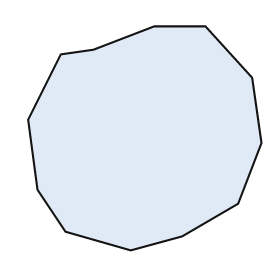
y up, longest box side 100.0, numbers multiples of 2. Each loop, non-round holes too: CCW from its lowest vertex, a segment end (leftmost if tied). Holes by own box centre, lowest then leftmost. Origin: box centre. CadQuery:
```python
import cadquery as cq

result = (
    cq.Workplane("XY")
    .moveTo(-6.0, -48.0)
    .lineTo(16.0, -42.0)
    .lineTo(40.0, -28.0)
    .lineTo(50.0, -2.0)
    .lineTo(46.0, 26.0)
    .lineTo(26.0, 48.0)
    .lineTo(4.0, 48.0)
    .lineTo(-22.0, 38.0)
    .lineTo(-36.0, 36.0)
    .lineTo(-50.0, 8.0)
    .lineTo(-46.0, -22.0)
    .lineTo(-34.0, -40.0)
    .close()
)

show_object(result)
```